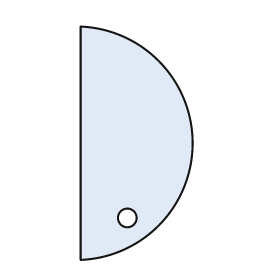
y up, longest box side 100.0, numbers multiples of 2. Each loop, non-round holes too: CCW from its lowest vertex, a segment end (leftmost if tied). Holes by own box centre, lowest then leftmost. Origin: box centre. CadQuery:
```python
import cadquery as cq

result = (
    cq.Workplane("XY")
    .moveTo(-24.0, -50.0)
    .threePointArc((24.0, 0.0), (-24.0, 50.0))
    .close()
    .moveTo(-4.0, -32.0)
    .circle(4.0)
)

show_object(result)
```